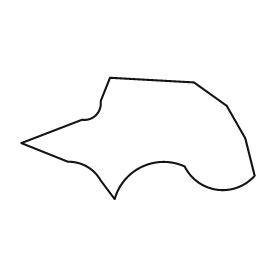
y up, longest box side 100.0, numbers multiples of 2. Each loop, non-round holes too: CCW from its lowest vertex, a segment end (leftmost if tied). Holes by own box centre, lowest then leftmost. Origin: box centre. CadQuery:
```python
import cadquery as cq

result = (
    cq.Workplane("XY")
    .moveTo(-10.0, -26.0)
    .threePointArc((2.0, -12.0), (20.0, -12.0))
    .threePointArc((34.0, -22.0), (50.0, -16.0))
    .lineTo(46.0, 0.0)
    .lineTo(38.0, 14.0)
    .lineTo(24.0, 24.0)
    .lineTo(-12.0, 26.0)
    .lineTo(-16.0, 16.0)
    .threePointArc((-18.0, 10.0), (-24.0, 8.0))
    .lineTo(-50.0, -2.0)
    .lineTo(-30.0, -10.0)
    .threePointArc((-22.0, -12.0), (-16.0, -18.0))
    .close()
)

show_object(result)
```